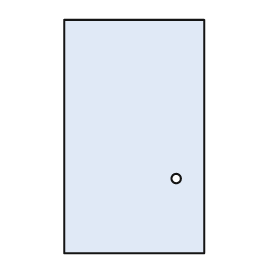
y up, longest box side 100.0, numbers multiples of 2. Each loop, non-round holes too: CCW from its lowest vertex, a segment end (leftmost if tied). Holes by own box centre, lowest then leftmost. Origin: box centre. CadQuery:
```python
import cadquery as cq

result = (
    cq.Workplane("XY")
    .moveTo(-30.0, -50.0)
    .lineTo(30.0, -50.0)
    .lineTo(30.0, 50.0)
    .lineTo(-30.0, 50.0)
    .close()
    .moveTo(18.0, -18.0)
    .circle(2.0)
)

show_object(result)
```